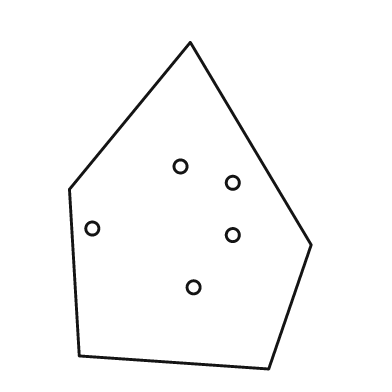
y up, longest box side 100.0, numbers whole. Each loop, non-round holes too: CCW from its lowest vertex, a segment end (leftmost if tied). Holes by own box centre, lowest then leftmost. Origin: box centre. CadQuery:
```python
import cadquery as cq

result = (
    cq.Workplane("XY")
    .moveTo(24.0, -50.0)
    .lineTo(37.0, -12.0)
    .lineTo(0.0, 50.0)
    .lineTo(-37.0, 5.0)
    .lineTo(-34.0, -46.0)
    .close()
    .moveTo(1.0, -25.0)
    .circle(2.0)
    .moveTo(13.0, -9.0)
    .circle(2.0)
    .moveTo(-30.0, -7.0)
    .circle(2.0)
    .moveTo(13.0, 7.0)
    .circle(2.0)
    .moveTo(-3.0, 12.0)
    .circle(2.0)
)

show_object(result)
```